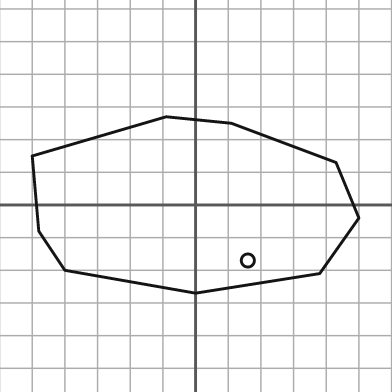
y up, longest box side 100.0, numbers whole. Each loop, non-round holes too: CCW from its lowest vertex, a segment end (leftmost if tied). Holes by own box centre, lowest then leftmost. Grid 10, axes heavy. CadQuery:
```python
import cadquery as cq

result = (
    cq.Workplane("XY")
    .moveTo(0.0, -27.0)
    .lineTo(38.0, -21.0)
    .lineTo(50.0, -4.0)
    .lineTo(43.0, 13.0)
    .lineTo(11.0, 25.0)
    .lineTo(-9.0, 27.0)
    .lineTo(-50.0, 15.0)
    .lineTo(-48.0, -8.0)
    .lineTo(-40.0, -20.0)
    .close()
    .moveTo(16.0, -17.0)
    .circle(2.0)
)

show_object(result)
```